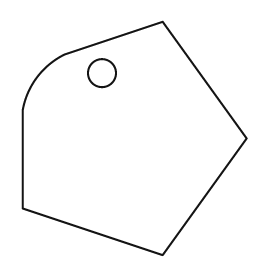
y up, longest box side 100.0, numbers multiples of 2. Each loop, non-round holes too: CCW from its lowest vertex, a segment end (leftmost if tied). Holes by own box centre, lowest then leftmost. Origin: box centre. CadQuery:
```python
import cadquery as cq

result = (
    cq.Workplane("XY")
    .moveTo(12.0, -50.0)
    .lineTo(48.0, 0.0)
    .lineTo(12.0, 50.0)
    .lineTo(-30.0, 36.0)
    .threePointArc((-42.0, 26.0), (-48.0, 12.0))
    .lineTo(-48.0, -30.0)
    .close()
    .moveTo(-14.0, 28.0)
    .circle(6.0)
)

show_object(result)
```